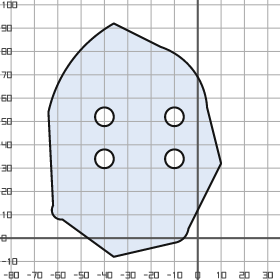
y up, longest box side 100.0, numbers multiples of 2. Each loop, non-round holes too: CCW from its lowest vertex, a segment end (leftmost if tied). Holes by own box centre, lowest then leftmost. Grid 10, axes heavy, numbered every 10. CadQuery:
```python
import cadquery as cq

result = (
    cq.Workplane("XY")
    .moveTo(-36.0, -8.0)
    .lineTo(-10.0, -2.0)
    .threePointArc((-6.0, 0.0), (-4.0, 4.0))
    .lineTo(10.0, 32.0)
    .lineTo(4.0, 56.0)
    .threePointArc((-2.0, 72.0), (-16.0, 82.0))
    .lineTo(-36.0, 92.0)
    .threePointArc((-54.0, 76.0), (-64.0, 54.0))
    .lineTo(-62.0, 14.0)
    .threePointArc((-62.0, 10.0), (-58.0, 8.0))
    .close()
    .moveTo(-40.0, 34.0)
    .circle(4.0)
    .moveTo(-10.0, 34.0)
    .circle(4.0)
    .moveTo(-40.0, 52.0)
    .circle(4.0)
    .moveTo(-10.0, 52.0)
    .circle(4.0)
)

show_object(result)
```